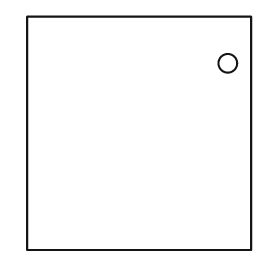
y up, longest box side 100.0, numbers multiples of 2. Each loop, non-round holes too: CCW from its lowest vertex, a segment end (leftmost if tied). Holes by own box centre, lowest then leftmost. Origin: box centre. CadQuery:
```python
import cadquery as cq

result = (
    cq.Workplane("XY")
    .moveTo(-48.0, -50.0)
    .lineTo(48.0, -50.0)
    .lineTo(48.0, 50.0)
    .lineTo(-48.0, 50.0)
    .close()
    .moveTo(38.0, 30.0)
    .circle(4.0)
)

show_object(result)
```